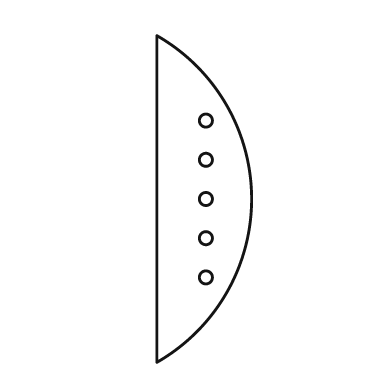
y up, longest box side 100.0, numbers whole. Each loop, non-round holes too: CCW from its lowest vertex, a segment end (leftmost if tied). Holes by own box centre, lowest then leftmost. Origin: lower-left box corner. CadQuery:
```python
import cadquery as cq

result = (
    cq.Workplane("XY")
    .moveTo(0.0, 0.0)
    .threePointArc((29.0, 50.0), (0.0, 100.0))
    .close()
    .moveTo(15.0, 26.0)
    .circle(2.0)
    .moveTo(15.0, 38.0)
    .circle(2.0)
    .moveTo(15.0, 50.0)
    .circle(2.0)
    .moveTo(15.0, 62.0)
    .circle(2.0)
    .moveTo(15.0, 74.0)
    .circle(2.0)
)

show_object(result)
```